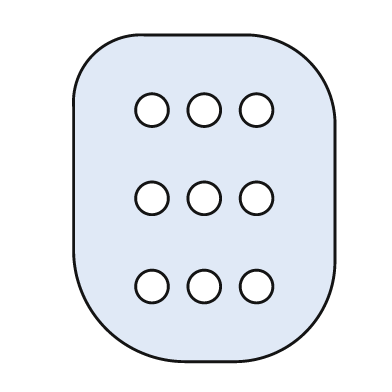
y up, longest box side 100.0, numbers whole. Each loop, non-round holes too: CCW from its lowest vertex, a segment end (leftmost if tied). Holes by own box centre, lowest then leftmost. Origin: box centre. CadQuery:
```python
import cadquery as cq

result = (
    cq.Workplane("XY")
    .moveTo(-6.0, -50.0)
    .lineTo(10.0, -50.0)
    .threePointArc((31.0, -41.0), (40.0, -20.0))
    .lineTo(40.0, 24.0)
    .threePointArc((32.0, 42.0), (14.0, 50.0))
    .lineTo(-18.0, 50.0)
    .threePointArc((-34.0, 44.0), (-40.0, 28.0))
    .lineTo(-40.0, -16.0)
    .threePointArc((-30.0, -40.0), (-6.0, -50.0))
    .close()
    .moveTo(-16.0, -27.0)
    .circle(5.0)
    .moveTo(0.0, -27.0)
    .circle(5.0)
    .moveTo(16.0, -27.0)
    .circle(5.0)
    .moveTo(-16.0, 0.0)
    .circle(5.0)
    .moveTo(0.0, 0.0)
    .circle(5.0)
    .moveTo(16.0, 0.0)
    .circle(5.0)
    .moveTo(-16.0, 27.0)
    .circle(5.0)
    .moveTo(0.0, 27.0)
    .circle(5.0)
    .moveTo(16.0, 27.0)
    .circle(5.0)
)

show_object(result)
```